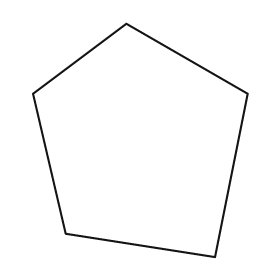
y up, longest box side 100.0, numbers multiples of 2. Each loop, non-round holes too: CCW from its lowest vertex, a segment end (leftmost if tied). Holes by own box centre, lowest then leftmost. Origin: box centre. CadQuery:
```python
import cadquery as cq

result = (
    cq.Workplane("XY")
    .moveTo(32.0, -50.0)
    .lineTo(46.0, 20.0)
    .lineTo(-6.0, 50.0)
    .lineTo(-46.0, 20.0)
    .lineTo(-32.0, -40.0)
    .close()
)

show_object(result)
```